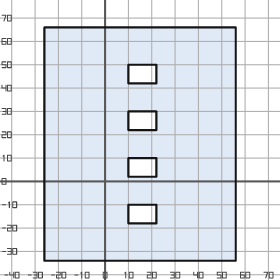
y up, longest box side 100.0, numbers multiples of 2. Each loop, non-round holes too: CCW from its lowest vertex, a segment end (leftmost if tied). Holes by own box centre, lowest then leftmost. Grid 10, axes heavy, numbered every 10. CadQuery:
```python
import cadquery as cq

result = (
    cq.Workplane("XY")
    .moveTo(-26.0, -34.0)
    .lineTo(56.0, -34.0)
    .lineTo(56.0, 66.0)
    .lineTo(-26.0, 66.0)
    .close()
    .moveTo(10.0, -18.0)
    .lineTo(22.0, -18.0)
    .lineTo(22.0, -10.0)
    .lineTo(10.0, -10.0)
    .close()
    .moveTo(10.0, 2.0)
    .lineTo(22.0, 2.0)
    .lineTo(22.0, 10.0)
    .lineTo(10.0, 10.0)
    .close()
    .moveTo(10.0, 22.0)
    .lineTo(22.0, 22.0)
    .lineTo(22.0, 30.0)
    .lineTo(10.0, 30.0)
    .close()
    .moveTo(10.0, 42.0)
    .lineTo(22.0, 42.0)
    .lineTo(22.0, 50.0)
    .lineTo(10.0, 50.0)
    .close()
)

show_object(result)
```